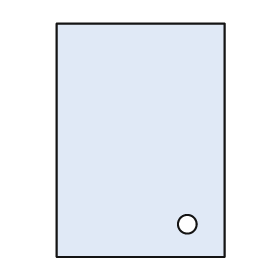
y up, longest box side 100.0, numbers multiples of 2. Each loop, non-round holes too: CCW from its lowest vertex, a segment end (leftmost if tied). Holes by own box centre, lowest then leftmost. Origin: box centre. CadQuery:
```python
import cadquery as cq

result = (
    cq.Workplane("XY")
    .moveTo(-36.0, -50.0)
    .lineTo(36.0, -50.0)
    .lineTo(36.0, 50.0)
    .lineTo(-36.0, 50.0)
    .close()
    .moveTo(20.0, -36.0)
    .circle(4.0)
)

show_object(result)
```